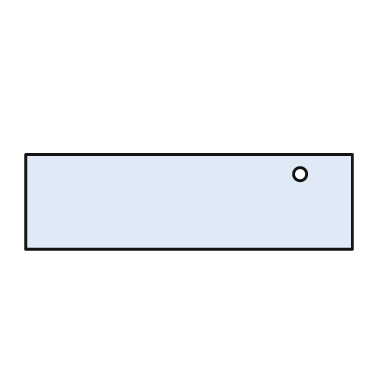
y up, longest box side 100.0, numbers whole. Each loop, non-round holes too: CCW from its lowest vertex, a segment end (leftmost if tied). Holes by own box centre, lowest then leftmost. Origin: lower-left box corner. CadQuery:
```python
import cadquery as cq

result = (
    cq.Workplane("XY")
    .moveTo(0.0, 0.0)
    .lineTo(100.0, 0.0)
    .lineTo(100.0, 29.0)
    .lineTo(0.0, 29.0)
    .close()
    .moveTo(84.0, 23.0)
    .circle(2.0)
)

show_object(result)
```